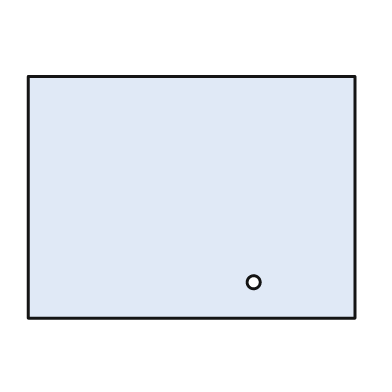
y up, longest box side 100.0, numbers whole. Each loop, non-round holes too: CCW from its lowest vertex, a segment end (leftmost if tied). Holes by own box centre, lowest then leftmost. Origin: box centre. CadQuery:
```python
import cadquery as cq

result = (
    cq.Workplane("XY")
    .moveTo(-50.0, -37.0)
    .lineTo(50.0, -37.0)
    .lineTo(50.0, 37.0)
    .lineTo(-50.0, 37.0)
    .close()
    .moveTo(19.0, -26.0)
    .circle(2.0)
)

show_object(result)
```